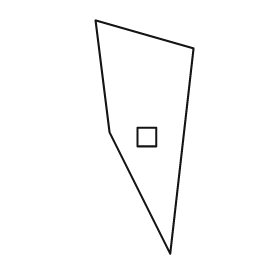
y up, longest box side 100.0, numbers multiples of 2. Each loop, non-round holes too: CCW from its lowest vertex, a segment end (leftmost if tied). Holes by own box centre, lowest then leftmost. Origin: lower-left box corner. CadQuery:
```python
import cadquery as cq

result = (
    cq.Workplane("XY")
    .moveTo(32.0, 0.0)
    .lineTo(42.0, 88.0)
    .lineTo(0.0, 100.0)
    .lineTo(6.0, 52.0)
    .close()
    .moveTo(18.0, 46.0)
    .lineTo(26.0, 46.0)
    .lineTo(26.0, 54.0)
    .lineTo(18.0, 54.0)
    .close()
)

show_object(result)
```